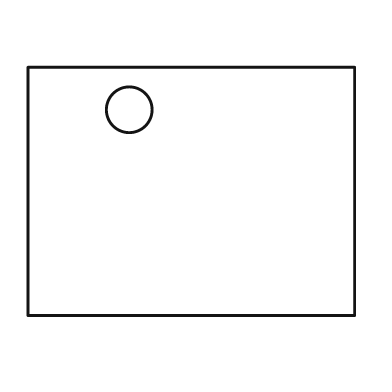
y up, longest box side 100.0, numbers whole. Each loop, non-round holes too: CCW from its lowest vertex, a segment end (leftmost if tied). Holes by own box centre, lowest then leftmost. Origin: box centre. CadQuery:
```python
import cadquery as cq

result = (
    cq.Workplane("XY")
    .moveTo(-50.0, -38.0)
    .lineTo(50.0, -38.0)
    .lineTo(50.0, 38.0)
    .lineTo(-50.0, 38.0)
    .close()
    .moveTo(-19.0, 25.0)
    .circle(7.0)
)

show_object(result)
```